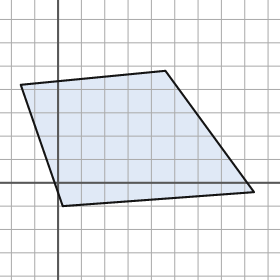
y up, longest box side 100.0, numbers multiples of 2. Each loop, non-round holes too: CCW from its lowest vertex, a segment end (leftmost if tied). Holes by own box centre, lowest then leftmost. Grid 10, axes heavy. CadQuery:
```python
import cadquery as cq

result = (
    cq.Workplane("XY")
    .moveTo(2.0, -10.0)
    .lineTo(84.0, -4.0)
    .lineTo(46.0, 48.0)
    .lineTo(-16.0, 42.0)
    .close()
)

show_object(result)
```